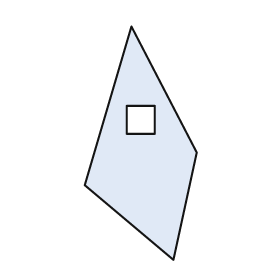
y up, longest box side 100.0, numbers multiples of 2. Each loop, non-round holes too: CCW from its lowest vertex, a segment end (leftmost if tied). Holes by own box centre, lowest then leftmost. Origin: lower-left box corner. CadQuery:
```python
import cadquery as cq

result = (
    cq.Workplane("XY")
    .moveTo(38.0, 0.0)
    .lineTo(48.0, 46.0)
    .lineTo(20.0, 100.0)
    .lineTo(0.0, 32.0)
    .close()
    .moveTo(18.0, 54.0)
    .lineTo(30.0, 54.0)
    .lineTo(30.0, 66.0)
    .lineTo(18.0, 66.0)
    .close()
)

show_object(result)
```